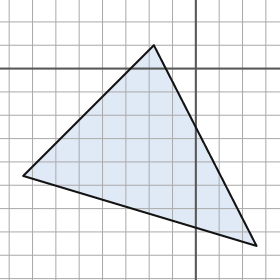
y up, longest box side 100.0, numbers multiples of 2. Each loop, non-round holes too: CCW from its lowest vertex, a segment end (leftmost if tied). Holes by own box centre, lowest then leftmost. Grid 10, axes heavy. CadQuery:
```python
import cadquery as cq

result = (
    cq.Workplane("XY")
    .moveTo(26.0, -76.0)
    .lineTo(-18.0, 10.0)
    .lineTo(-74.0, -46.0)
    .close()
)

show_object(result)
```